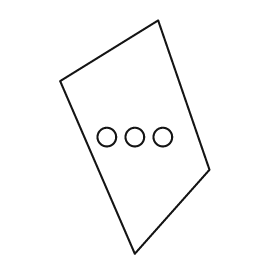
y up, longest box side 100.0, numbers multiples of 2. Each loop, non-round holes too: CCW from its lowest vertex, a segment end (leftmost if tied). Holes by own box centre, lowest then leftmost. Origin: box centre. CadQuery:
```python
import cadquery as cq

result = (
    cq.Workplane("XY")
    .moveTo(0.0, -50.0)
    .lineTo(32.0, -14.0)
    .lineTo(10.0, 50.0)
    .lineTo(-32.0, 24.0)
    .close()
    .moveTo(-12.0, 0.0)
    .circle(4.0)
    .moveTo(0.0, 0.0)
    .circle(4.0)
    .moveTo(12.0, 0.0)
    .circle(4.0)
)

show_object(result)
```